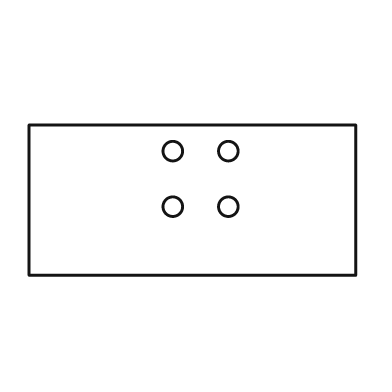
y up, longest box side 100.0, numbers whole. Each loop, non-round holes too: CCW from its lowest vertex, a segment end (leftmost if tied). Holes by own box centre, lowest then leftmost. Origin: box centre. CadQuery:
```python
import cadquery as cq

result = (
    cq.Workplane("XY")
    .moveTo(-50.0, -23.0)
    .lineTo(50.0, -23.0)
    .lineTo(50.0, 23.0)
    .lineTo(-50.0, 23.0)
    .close()
    .moveTo(-6.0, -2.0)
    .circle(3.0)
    .moveTo(11.0, -2.0)
    .circle(3.0)
    .moveTo(-6.0, 15.0)
    .circle(3.0)
    .moveTo(11.0, 15.0)
    .circle(3.0)
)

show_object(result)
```